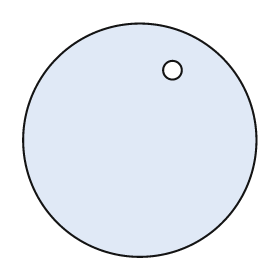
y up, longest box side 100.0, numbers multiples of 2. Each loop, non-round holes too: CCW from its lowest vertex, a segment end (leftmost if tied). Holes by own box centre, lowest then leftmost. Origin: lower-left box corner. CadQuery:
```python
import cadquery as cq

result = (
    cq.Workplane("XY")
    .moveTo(50.0, 50.0)
    .circle(50.0)
    .moveTo(64.0, 80.0)
    .circle(4.0)
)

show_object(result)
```